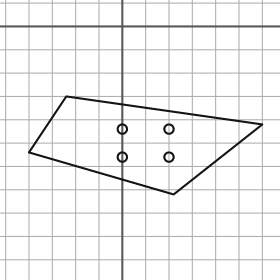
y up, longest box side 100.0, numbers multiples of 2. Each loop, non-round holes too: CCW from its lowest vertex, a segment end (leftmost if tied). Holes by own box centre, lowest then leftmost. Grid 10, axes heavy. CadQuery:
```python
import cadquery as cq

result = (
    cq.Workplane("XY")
    .moveTo(22.0, -72.0)
    .lineTo(60.0, -42.0)
    .lineTo(-24.0, -30.0)
    .lineTo(-40.0, -54.0)
    .close()
    .moveTo(0.0, -56.0)
    .circle(2.0)
    .moveTo(20.0, -56.0)
    .circle(2.0)
    .moveTo(0.0, -44.0)
    .circle(2.0)
    .moveTo(20.0, -44.0)
    .circle(2.0)
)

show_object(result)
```